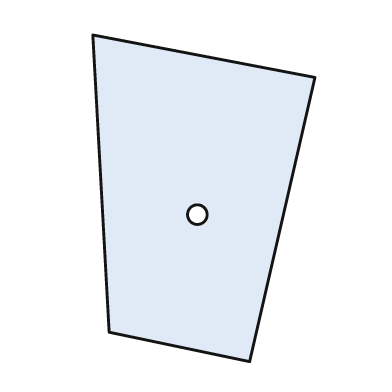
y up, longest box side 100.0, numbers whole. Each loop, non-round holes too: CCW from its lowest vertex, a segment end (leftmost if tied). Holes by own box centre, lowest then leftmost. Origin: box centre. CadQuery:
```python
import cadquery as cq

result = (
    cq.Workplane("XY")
    .moveTo(14.0, -50.0)
    .lineTo(34.0, 37.0)
    .lineTo(-34.0, 50.0)
    .lineTo(-29.0, -41.0)
    .close()
    .moveTo(-2.0, -5.0)
    .circle(3.0)
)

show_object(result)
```